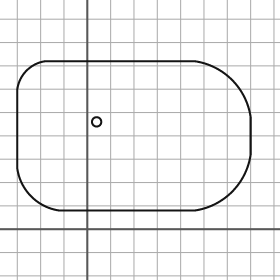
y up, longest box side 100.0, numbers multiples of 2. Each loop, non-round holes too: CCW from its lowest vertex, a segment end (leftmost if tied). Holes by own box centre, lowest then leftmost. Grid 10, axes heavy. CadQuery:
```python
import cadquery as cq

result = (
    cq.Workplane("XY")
    .moveTo(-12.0, 8.0)
    .lineTo(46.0, 8.0)
    .threePointArc((62.0, 16.0), (70.0, 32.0))
    .lineTo(70.0, 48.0)
    .threePointArc((62.0, 64.0), (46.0, 72.0))
    .lineTo(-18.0, 72.0)
    .threePointArc((-26.0, 68.0), (-30.0, 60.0))
    .lineTo(-30.0, 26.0)
    .threePointArc((-24.0, 14.0), (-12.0, 8.0))
    .close()
    .moveTo(4.0, 46.0)
    .circle(2.0)
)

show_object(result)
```